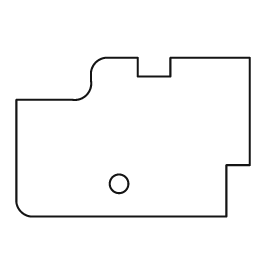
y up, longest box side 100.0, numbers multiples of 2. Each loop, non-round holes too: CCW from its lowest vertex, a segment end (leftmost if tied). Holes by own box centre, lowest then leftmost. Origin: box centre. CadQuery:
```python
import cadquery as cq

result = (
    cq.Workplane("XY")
    .moveTo(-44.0, -34.0)
    .lineTo(40.0, -34.0)
    .lineTo(40.0, -12.0)
    .lineTo(50.0, -12.0)
    .lineTo(50.0, 34.0)
    .lineTo(16.0, 34.0)
    .lineTo(16.0, 26.0)
    .lineTo(2.0, 26.0)
    .lineTo(2.0, 34.0)
    .lineTo(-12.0, 34.0)
    .threePointArc((-16.0, 32.0), (-18.0, 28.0))
    .lineTo(-18.0, 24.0)
    .threePointArc((-20.0, 18.0), (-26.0, 16.0))
    .lineTo(-50.0, 16.0)
    .lineTo(-50.0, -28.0)
    .threePointArc((-48.0, -32.0), (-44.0, -34.0))
    .close()
    .moveTo(-6.0, -20.0)
    .circle(4.0)
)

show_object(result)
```